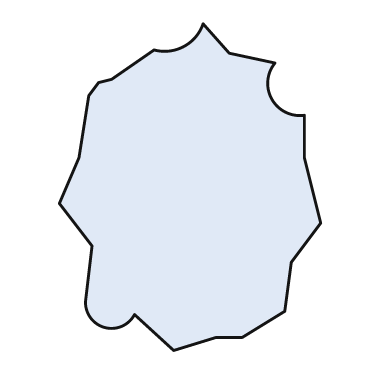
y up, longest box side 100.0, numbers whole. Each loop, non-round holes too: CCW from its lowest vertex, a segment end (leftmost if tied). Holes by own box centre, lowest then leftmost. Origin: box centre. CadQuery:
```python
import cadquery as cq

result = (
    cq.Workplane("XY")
    .moveTo(-5.0, -50.0)
    .lineTo(8.0, -46.0)
    .lineTo(16.0, -46.0)
    .lineTo(29.0, -38.0)
    .lineTo(31.0, -23.0)
    .lineTo(40.0, -11.0)
    .lineTo(35.0, 9.0)
    .lineTo(35.0, 22.0)
    .threePointArc((25.0, 27.0), (26.0, 38.0))
    .lineTo(12.0, 41.0)
    .lineTo(4.0, 50.0)
    .threePointArc((-2.0, 43.0), (-11.0, 42.0))
    .lineTo(-24.0, 33.0)
    .lineTo(-28.0, 32.0)
    .lineTo(-31.0, 28.0)
    .lineTo(-34.0, 9.0)
    .lineTo(-40.0, -5.0)
    .lineTo(-30.0, -18.0)
    .lineTo(-32.0, -35.0)
    .threePointArc((-26.0, -43.0), (-17.0, -39.0))
    .close()
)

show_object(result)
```